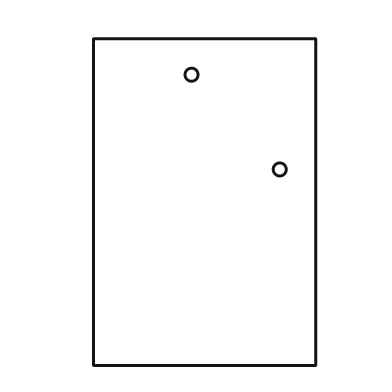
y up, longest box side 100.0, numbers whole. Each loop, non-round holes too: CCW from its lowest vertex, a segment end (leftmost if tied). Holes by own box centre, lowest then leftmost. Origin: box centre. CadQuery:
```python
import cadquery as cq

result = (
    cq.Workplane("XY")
    .moveTo(-34.0, -50.0)
    .lineTo(34.0, -50.0)
    .lineTo(34.0, 50.0)
    .lineTo(-34.0, 50.0)
    .close()
    .moveTo(23.0, 10.0)
    .circle(2.0)
    .moveTo(-4.0, 39.0)
    .circle(2.0)
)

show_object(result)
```